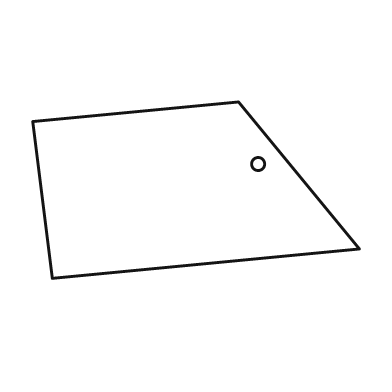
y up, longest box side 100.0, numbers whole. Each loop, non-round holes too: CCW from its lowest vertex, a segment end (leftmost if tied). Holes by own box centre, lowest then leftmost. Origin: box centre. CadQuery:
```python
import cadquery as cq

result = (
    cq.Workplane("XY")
    .moveTo(-44.0, -27.0)
    .lineTo(50.0, -18.0)
    .lineTo(13.0, 27.0)
    .lineTo(-50.0, 21.0)
    .close()
    .moveTo(19.0, 8.0)
    .circle(2.0)
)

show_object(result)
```